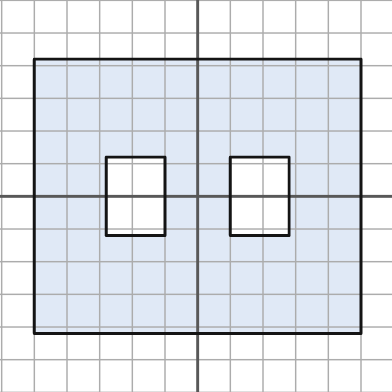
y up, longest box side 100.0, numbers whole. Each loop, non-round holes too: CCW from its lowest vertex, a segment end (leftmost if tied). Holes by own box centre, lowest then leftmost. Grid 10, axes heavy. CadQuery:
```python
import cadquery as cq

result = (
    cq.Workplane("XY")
    .moveTo(-50.0, -42.0)
    .lineTo(50.0, -42.0)
    .lineTo(50.0, 42.0)
    .lineTo(-50.0, 42.0)
    .close()
    .moveTo(-28.0, -12.0)
    .lineTo(-10.0, -12.0)
    .lineTo(-10.0, 12.0)
    .lineTo(-28.0, 12.0)
    .close()
    .moveTo(10.0, -12.0)
    .lineTo(28.0, -12.0)
    .lineTo(28.0, 12.0)
    .lineTo(10.0, 12.0)
    .close()
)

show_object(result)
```